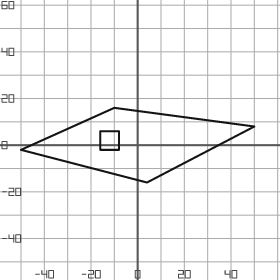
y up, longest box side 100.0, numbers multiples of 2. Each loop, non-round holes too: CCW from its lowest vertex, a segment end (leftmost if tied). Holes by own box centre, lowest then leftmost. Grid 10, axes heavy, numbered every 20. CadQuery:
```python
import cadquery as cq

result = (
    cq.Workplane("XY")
    .moveTo(4.0, -16.0)
    .lineTo(50.0, 8.0)
    .lineTo(-10.0, 16.0)
    .lineTo(-50.0, -2.0)
    .close()
    .moveTo(-16.0, -2.0)
    .lineTo(-8.0, -2.0)
    .lineTo(-8.0, 6.0)
    .lineTo(-16.0, 6.0)
    .close()
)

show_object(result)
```